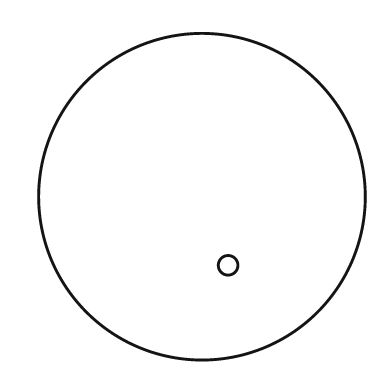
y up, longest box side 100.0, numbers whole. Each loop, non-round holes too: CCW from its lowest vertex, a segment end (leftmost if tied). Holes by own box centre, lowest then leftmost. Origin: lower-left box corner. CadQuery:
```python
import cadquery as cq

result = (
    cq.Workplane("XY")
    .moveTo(50.0, 50.0)
    .circle(50.0)
    .moveTo(58.0, 29.0)
    .circle(3.0)
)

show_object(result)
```